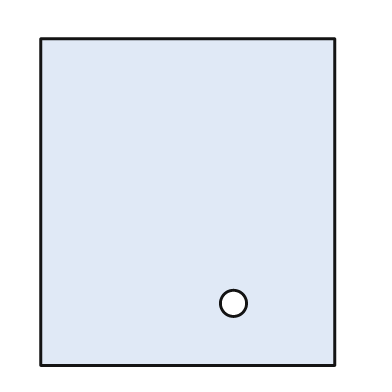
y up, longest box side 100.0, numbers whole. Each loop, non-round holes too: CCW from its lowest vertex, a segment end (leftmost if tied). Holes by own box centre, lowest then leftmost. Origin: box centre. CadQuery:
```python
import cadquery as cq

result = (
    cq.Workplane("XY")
    .moveTo(-45.0, -50.0)
    .lineTo(45.0, -50.0)
    .lineTo(45.0, 50.0)
    .lineTo(-45.0, 50.0)
    .close()
    .moveTo(14.0, -31.0)
    .circle(4.0)
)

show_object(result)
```